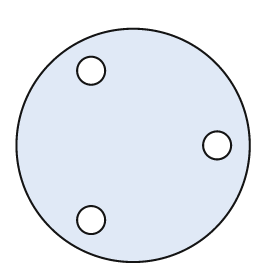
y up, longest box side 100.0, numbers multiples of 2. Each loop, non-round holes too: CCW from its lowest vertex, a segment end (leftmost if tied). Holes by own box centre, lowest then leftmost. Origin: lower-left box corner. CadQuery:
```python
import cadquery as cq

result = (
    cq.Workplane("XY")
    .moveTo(50.0, 50.0)
    .circle(50.0)
    .moveTo(32.0, 18.0)
    .circle(6.0)
    .moveTo(86.0, 50.0)
    .circle(6.0)
    .moveTo(32.0, 82.0)
    .circle(6.0)
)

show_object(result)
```